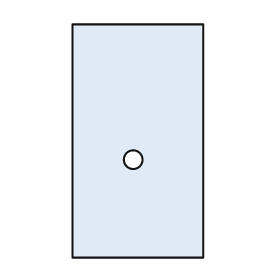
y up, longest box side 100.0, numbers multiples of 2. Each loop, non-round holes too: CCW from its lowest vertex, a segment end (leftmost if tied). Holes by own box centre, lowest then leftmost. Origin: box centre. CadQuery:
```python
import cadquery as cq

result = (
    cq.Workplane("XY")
    .moveTo(-28.0, -50.0)
    .lineTo(28.0, -50.0)
    .lineTo(28.0, 50.0)
    .lineTo(-28.0, 50.0)
    .close()
    .moveTo(-2.0, -8.0)
    .circle(4.0)
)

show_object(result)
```